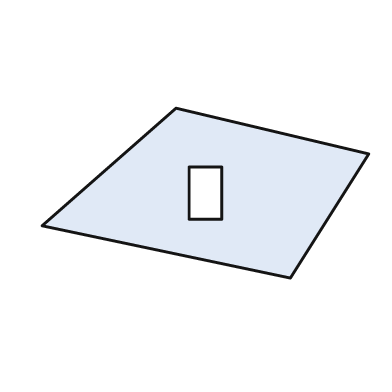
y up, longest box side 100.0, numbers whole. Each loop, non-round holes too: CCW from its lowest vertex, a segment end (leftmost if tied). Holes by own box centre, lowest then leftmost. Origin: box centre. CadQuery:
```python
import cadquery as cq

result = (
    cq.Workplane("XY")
    .moveTo(26.0, -26.0)
    .lineTo(50.0, 12.0)
    .lineTo(-9.0, 26.0)
    .lineTo(-50.0, -10.0)
    .close()
    .moveTo(-5.0, -8.0)
    .lineTo(5.0, -8.0)
    .lineTo(5.0, 8.0)
    .lineTo(-5.0, 8.0)
    .close()
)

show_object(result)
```